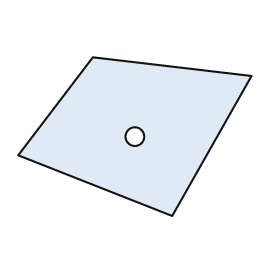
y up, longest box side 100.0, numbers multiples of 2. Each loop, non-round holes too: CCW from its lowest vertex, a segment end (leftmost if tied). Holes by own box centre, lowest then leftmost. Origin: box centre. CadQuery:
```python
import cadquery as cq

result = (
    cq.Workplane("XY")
    .moveTo(16.0, -34.0)
    .lineTo(50.0, 26.0)
    .lineTo(-18.0, 34.0)
    .lineTo(-50.0, -8.0)
    .close()
    .moveTo(0.0, 0.0)
    .circle(4.0)
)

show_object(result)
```